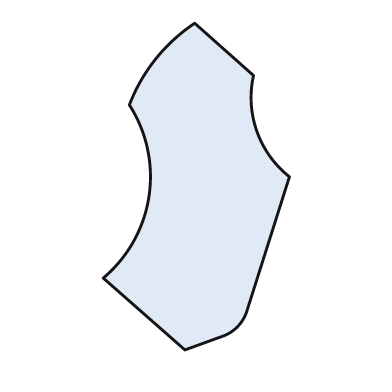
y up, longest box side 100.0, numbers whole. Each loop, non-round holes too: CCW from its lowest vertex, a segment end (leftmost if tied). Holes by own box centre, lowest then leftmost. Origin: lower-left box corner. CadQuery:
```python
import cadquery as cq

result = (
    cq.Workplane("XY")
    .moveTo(25.0, 0.0)
    .lineTo(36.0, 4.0)
    .threePointArc((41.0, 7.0), (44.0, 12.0))
    .lineTo(57.0, 53.0)
    .threePointArc((47.0, 67.0), (46.0, 84.0))
    .lineTo(28.0, 100.0)
    .threePointArc((16.0, 89.0), (8.0, 75.0))
    .threePointArc((14.0, 47.0), (0.0, 22.0))
    .close()
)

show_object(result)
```